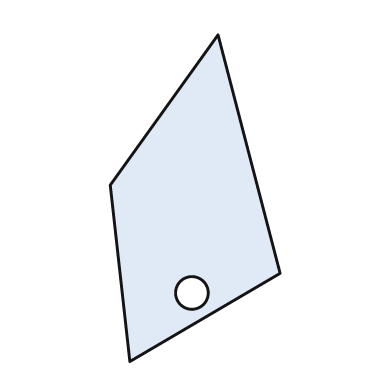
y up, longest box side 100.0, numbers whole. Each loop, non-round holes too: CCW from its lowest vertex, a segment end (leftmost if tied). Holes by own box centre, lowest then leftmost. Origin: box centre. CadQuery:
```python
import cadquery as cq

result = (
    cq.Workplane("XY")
    .moveTo(-20.0, -50.0)
    .lineTo(26.0, -23.0)
    .lineTo(7.0, 50.0)
    .lineTo(-26.0, 4.0)
    .close()
    .moveTo(-1.0, -29.0)
    .circle(5.0)
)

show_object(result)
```